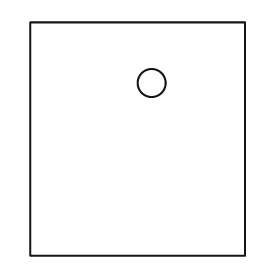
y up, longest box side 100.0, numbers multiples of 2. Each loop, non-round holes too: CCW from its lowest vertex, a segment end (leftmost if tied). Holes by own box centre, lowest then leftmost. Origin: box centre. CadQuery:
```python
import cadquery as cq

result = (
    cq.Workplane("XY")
    .moveTo(-46.0, -50.0)
    .lineTo(46.0, -50.0)
    .lineTo(46.0, 50.0)
    .lineTo(-46.0, 50.0)
    .close()
    .moveTo(6.0, 24.0)
    .circle(6.0)
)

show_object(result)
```